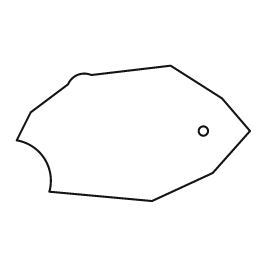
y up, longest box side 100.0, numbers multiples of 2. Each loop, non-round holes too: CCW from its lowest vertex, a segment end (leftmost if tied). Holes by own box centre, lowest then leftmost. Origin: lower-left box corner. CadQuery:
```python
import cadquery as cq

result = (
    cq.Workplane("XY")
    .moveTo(58.0, 0.0)
    .lineTo(84.0, 12.0)
    .lineTo(100.0, 30.0)
    .lineTo(88.0, 44.0)
    .lineTo(66.0, 58.0)
    .lineTo(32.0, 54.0)
    .threePointArc((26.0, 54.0), (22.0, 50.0))
    .lineTo(6.0, 38.0)
    .lineTo(0.0, 26.0)
    .threePointArc((12.0, 18.0), (14.0, 4.0))
    .close()
    .moveTo(80.0, 30.0)
    .circle(2.0)
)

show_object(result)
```